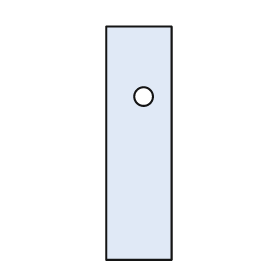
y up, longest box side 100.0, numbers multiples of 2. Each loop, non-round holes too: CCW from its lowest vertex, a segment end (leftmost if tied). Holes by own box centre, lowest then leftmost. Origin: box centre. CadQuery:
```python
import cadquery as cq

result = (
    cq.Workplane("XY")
    .moveTo(-14.0, -50.0)
    .lineTo(14.0, -50.0)
    .lineTo(14.0, 50.0)
    .lineTo(-14.0, 50.0)
    .close()
    .moveTo(2.0, 20.0)
    .circle(4.0)
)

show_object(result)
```